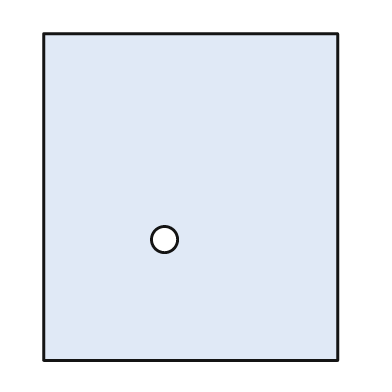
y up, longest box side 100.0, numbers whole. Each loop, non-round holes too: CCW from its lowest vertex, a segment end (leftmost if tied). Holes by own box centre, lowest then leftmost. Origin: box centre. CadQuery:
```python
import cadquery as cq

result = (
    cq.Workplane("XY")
    .moveTo(-45.0, -50.0)
    .lineTo(45.0, -50.0)
    .lineTo(45.0, 50.0)
    .lineTo(-45.0, 50.0)
    .close()
    .moveTo(-8.0, -13.0)
    .circle(4.0)
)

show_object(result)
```